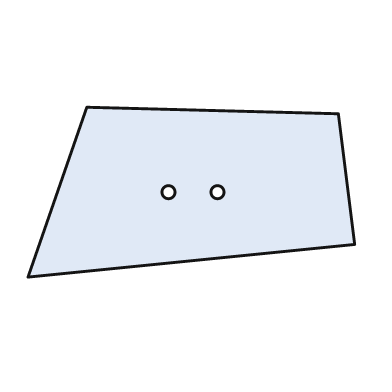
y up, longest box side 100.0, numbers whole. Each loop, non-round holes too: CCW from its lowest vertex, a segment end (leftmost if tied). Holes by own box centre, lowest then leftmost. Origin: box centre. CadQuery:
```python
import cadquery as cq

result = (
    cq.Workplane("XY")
    .moveTo(-50.0, -26.0)
    .lineTo(50.0, -16.0)
    .lineTo(45.0, 24.0)
    .lineTo(-32.0, 26.0)
    .close()
    .moveTo(-7.0, 0.0)
    .circle(2.0)
    .moveTo(8.0, 0.0)
    .circle(2.0)
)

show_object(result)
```